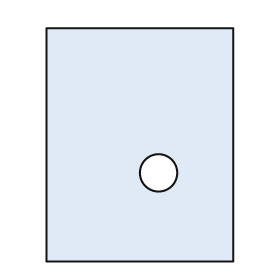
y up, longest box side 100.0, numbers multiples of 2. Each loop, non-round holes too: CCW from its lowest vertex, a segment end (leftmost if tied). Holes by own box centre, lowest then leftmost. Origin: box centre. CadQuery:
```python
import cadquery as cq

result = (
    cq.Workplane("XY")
    .moveTo(-40.0, -50.0)
    .lineTo(40.0, -50.0)
    .lineTo(40.0, 50.0)
    .lineTo(-40.0, 50.0)
    .close()
    .moveTo(8.0, -12.0)
    .circle(8.0)
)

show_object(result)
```